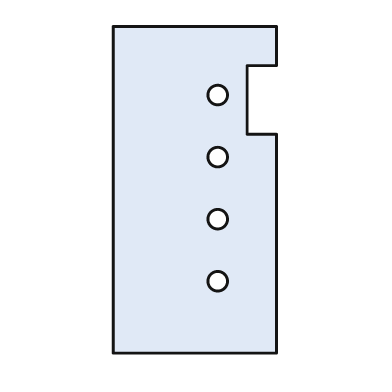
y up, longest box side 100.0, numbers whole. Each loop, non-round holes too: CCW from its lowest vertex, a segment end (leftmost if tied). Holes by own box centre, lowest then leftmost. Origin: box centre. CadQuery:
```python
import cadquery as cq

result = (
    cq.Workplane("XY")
    .moveTo(-25.0, -50.0)
    .lineTo(25.0, -50.0)
    .lineTo(25.0, 17.0)
    .lineTo(16.0, 17.0)
    .lineTo(16.0, 38.0)
    .lineTo(25.0, 38.0)
    .lineTo(25.0, 50.0)
    .lineTo(-25.0, 50.0)
    .close()
    .moveTo(7.0, -28.0)
    .circle(3.0)
    .moveTo(7.0, -9.0)
    .circle(3.0)
    .moveTo(7.0, 10.0)
    .circle(3.0)
    .moveTo(7.0, 29.0)
    .circle(3.0)
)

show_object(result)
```